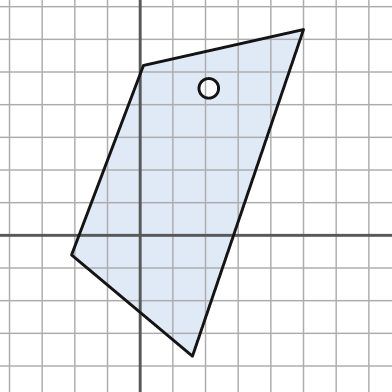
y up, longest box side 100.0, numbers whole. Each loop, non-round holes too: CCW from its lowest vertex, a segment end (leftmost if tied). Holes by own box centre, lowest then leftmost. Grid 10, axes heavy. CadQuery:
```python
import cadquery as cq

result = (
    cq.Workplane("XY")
    .moveTo(16.0, -37.0)
    .lineTo(50.0, 63.0)
    .lineTo(1.0, 52.0)
    .lineTo(-21.0, -6.0)
    .close()
    .moveTo(21.0, 45.0)
    .circle(3.0)
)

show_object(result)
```